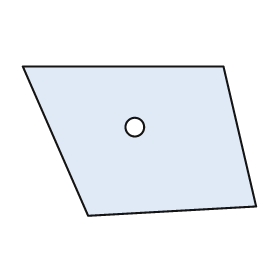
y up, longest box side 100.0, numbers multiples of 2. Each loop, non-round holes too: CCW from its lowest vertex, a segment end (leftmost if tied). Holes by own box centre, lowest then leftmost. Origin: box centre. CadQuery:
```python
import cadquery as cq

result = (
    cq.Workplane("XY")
    .moveTo(-22.0, -32.0)
    .lineTo(50.0, -28.0)
    .lineTo(36.0, 32.0)
    .lineTo(-50.0, 32.0)
    .close()
    .moveTo(-2.0, 6.0)
    .circle(4.0)
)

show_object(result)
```